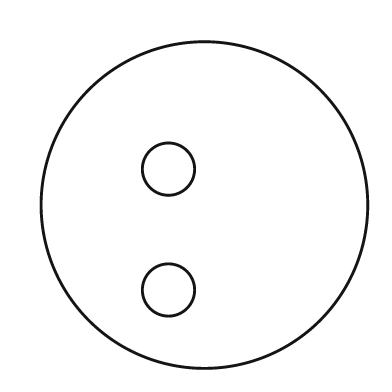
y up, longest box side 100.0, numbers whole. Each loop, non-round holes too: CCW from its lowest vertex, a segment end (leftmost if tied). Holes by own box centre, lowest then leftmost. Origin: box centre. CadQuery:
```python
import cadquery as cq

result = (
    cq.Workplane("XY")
    .moveTo(0.0, 0.0)
    .circle(50.0)
    .moveTo(-11.0, -26.0)
    .circle(8.0)
    .moveTo(-11.0, 11.0)
    .circle(8.0)
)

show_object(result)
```